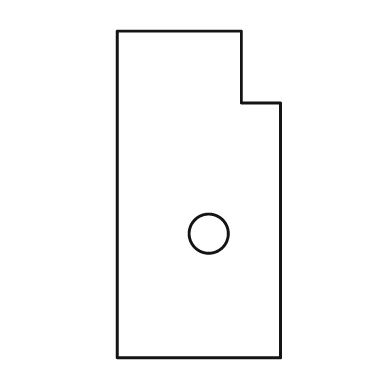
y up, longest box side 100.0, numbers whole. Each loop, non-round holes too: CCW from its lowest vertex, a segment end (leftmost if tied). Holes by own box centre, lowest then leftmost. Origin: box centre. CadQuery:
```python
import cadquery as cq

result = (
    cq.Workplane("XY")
    .moveTo(-25.0, -50.0)
    .lineTo(25.0, -50.0)
    .lineTo(25.0, 28.0)
    .lineTo(13.0, 28.0)
    .lineTo(13.0, 50.0)
    .lineTo(-25.0, 50.0)
    .close()
    .moveTo(3.0, -12.0)
    .circle(6.0)
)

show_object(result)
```